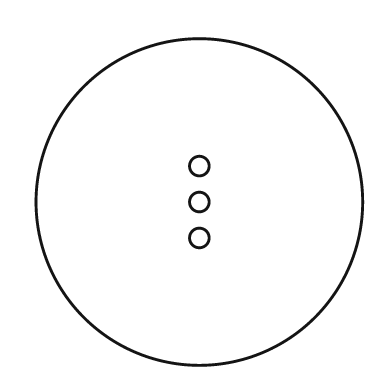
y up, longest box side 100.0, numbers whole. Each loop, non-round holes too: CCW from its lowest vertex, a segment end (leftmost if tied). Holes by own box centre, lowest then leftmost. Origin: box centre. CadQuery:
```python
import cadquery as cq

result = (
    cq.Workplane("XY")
    .moveTo(0.0, 0.0)
    .circle(50.0)
    .moveTo(0.0, -11.0)
    .circle(3.0)
    .moveTo(0.0, 0.0)
    .circle(3.0)
    .moveTo(0.0, 11.0)
    .circle(3.0)
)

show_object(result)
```